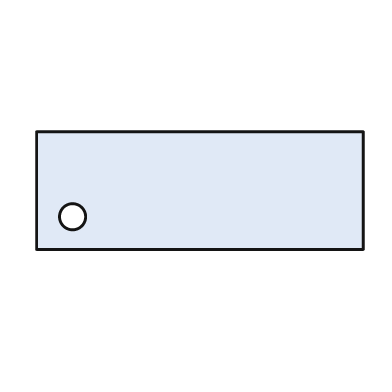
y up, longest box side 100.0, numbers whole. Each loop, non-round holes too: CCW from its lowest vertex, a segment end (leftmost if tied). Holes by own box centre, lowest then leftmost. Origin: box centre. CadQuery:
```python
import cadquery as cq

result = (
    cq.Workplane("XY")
    .moveTo(-50.0, -18.0)
    .lineTo(50.0, -18.0)
    .lineTo(50.0, 18.0)
    .lineTo(-50.0, 18.0)
    .close()
    .moveTo(-39.0, -8.0)
    .circle(4.0)
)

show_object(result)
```